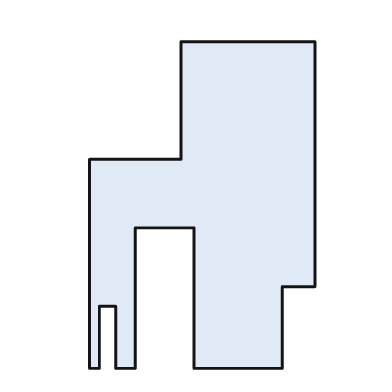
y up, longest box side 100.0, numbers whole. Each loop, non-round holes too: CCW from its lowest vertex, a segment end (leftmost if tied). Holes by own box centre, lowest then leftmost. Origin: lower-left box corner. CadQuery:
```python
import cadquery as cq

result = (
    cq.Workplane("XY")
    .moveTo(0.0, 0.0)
    .lineTo(3.0, 0.0)
    .lineTo(3.0, 19.0)
    .lineTo(8.0, 19.0)
    .lineTo(8.0, 0.0)
    .lineTo(14.0, 0.0)
    .lineTo(14.0, 43.0)
    .lineTo(32.0, 43.0)
    .lineTo(32.0, 0.0)
    .lineTo(59.0, 0.0)
    .lineTo(59.0, 25.0)
    .lineTo(69.0, 25.0)
    .lineTo(69.0, 100.0)
    .lineTo(28.0, 100.0)
    .lineTo(28.0, 64.0)
    .lineTo(0.0, 64.0)
    .close()
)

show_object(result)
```